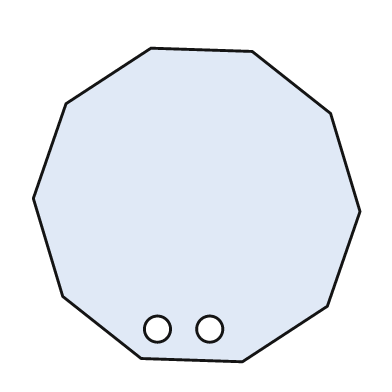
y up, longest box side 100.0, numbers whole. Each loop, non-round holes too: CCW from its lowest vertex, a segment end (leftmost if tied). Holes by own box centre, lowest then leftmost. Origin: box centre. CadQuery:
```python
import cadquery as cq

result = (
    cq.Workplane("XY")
    .moveTo(14.0, -48.0)
    .lineTo(40.0, -31.0)
    .lineTo(50.0, -2.0)
    .lineTo(41.0, 28.0)
    .lineTo(17.0, 47.0)
    .lineTo(-14.0, 48.0)
    .lineTo(-40.0, 31.0)
    .lineTo(-50.0, 2.0)
    .lineTo(-41.0, -28.0)
    .lineTo(-17.0, -47.0)
    .close()
    .moveTo(-12.0, -38.0)
    .circle(4.0)
    .moveTo(4.0, -38.0)
    .circle(4.0)
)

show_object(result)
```